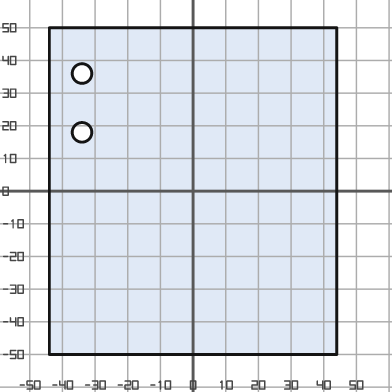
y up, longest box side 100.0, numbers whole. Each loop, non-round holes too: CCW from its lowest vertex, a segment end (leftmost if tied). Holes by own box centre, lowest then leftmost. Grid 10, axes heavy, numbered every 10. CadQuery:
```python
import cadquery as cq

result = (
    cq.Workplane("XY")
    .moveTo(-44.0, -50.0)
    .lineTo(44.0, -50.0)
    .lineTo(44.0, 50.0)
    .lineTo(-44.0, 50.0)
    .close()
    .moveTo(-34.0, 18.0)
    .circle(3.0)
    .moveTo(-34.0, 36.0)
    .circle(3.0)
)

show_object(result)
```